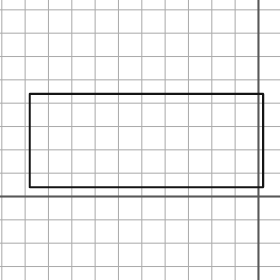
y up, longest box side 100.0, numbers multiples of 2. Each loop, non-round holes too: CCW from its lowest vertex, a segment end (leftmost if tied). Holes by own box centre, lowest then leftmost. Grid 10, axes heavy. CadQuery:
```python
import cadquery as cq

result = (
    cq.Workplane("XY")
    .moveTo(-98.0, 4.0)
    .lineTo(2.0, 4.0)
    .lineTo(2.0, 44.0)
    .lineTo(-98.0, 44.0)
    .close()
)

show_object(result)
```